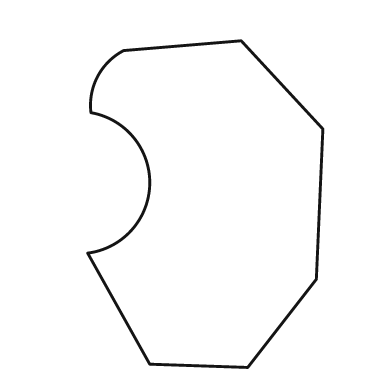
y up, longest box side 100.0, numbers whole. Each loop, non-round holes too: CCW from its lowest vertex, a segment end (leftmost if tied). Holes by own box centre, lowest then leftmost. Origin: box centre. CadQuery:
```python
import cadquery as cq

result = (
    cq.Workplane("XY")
    .moveTo(13.0, -50.0)
    .lineTo(34.0, -23.0)
    .lineTo(36.0, 23.0)
    .lineTo(11.0, 50.0)
    .lineTo(-25.0, 47.0)
    .threePointArc((-33.0, 39.0), (-35.0, 28.0))
    .threePointArc((-17.0, 6.0), (-36.0, -15.0))
    .lineTo(-17.0, -49.0)
    .close()
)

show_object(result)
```